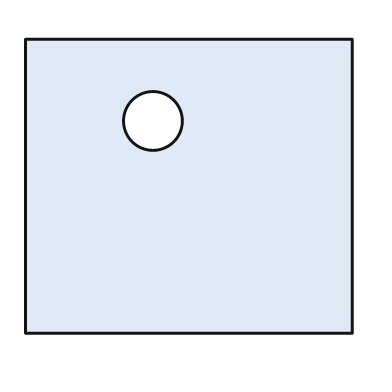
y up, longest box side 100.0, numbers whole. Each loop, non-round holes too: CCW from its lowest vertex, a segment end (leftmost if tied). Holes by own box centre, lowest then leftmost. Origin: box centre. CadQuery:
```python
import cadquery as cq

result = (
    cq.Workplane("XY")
    .moveTo(-50.0, -45.0)
    .lineTo(50.0, -45.0)
    .lineTo(50.0, 45.0)
    .lineTo(-50.0, 45.0)
    .close()
    .moveTo(-11.0, 20.0)
    .circle(9.0)
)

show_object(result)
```